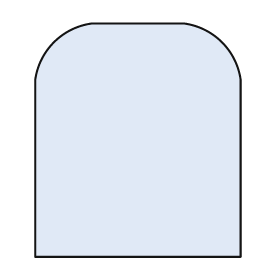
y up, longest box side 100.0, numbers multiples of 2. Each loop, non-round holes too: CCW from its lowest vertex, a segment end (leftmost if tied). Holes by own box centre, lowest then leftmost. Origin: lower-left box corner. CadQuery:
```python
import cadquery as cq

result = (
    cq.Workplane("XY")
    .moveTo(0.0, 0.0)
    .lineTo(88.0, 0.0)
    .lineTo(88.0, 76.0)
    .threePointArc((80.0, 92.0), (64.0, 100.0))
    .lineTo(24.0, 100.0)
    .threePointArc((8.0, 92.0), (0.0, 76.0))
    .close()
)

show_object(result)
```